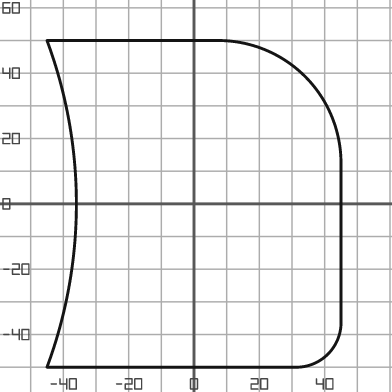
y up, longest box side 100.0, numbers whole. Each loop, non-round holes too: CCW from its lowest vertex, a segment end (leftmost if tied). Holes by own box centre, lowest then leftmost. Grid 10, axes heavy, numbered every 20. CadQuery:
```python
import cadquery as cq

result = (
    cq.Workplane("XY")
    .moveTo(-45.0, -50.0)
    .lineTo(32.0, -50.0)
    .threePointArc((41.0, -46.0), (45.0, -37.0))
    .lineTo(45.0, 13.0)
    .threePointArc((34.0, 39.0), (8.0, 50.0))
    .lineTo(-45.0, 50.0)
    .threePointArc((-36.0, 0.0), (-45.0, -50.0))
    .close()
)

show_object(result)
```